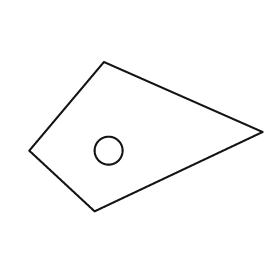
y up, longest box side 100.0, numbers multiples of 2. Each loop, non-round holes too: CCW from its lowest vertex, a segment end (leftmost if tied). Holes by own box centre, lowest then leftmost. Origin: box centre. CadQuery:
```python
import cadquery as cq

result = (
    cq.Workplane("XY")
    .moveTo(-22.0, -32.0)
    .lineTo(50.0, 2.0)
    .lineTo(-18.0, 32.0)
    .lineTo(-50.0, -6.0)
    .close()
    .moveTo(-16.0, -6.0)
    .circle(6.0)
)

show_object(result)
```